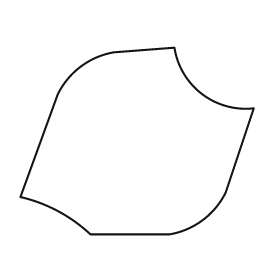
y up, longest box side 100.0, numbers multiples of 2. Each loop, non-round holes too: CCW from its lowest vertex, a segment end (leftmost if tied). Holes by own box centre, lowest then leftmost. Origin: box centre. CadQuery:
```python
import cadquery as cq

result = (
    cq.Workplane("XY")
    .moveTo(-20.0, -40.0)
    .lineTo(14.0, -40.0)
    .threePointArc((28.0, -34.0), (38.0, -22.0))
    .lineTo(50.0, 14.0)
    .threePointArc((28.0, 20.0), (16.0, 40.0))
    .lineTo(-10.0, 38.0)
    .threePointArc((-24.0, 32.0), (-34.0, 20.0))
    .lineTo(-50.0, -24.0)
    .threePointArc((-34.0, -30.0), (-20.0, -40.0))
    .close()
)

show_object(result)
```